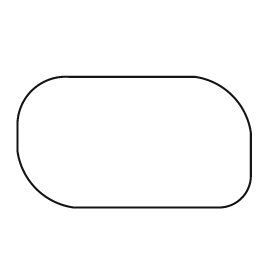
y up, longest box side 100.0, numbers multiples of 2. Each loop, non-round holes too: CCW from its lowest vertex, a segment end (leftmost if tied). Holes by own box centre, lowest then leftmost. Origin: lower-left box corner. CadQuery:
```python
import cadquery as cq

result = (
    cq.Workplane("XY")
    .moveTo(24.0, 0.0)
    .lineTo(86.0, 0.0)
    .threePointArc((96.0, 4.0), (100.0, 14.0))
    .lineTo(100.0, 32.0)
    .threePointArc((92.0, 48.0), (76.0, 56.0))
    .lineTo(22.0, 56.0)
    .threePointArc((6.0, 50.0), (0.0, 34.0))
    .lineTo(0.0, 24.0)
    .threePointArc((8.0, 8.0), (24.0, 0.0))
    .close()
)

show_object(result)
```